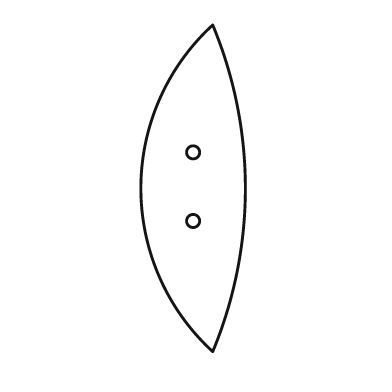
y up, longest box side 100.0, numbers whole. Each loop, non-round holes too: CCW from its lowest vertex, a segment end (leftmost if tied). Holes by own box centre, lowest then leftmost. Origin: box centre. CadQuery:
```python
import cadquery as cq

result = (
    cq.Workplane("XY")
    .moveTo(6.0, -50.0)
    .threePointArc((16.0, 0.0), (6.0, 50.0))
    .threePointArc((-16.0, 0.0), (6.0, -50.0))
    .close()
    .moveTo(0.0, -10.0)
    .circle(2.0)
    .moveTo(0.0, 11.0)
    .circle(2.0)
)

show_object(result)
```